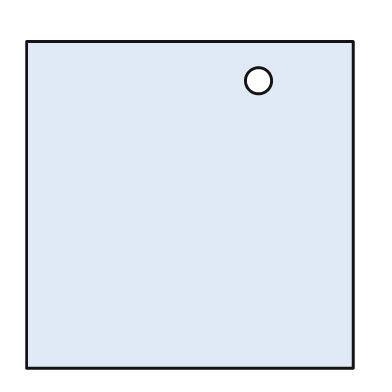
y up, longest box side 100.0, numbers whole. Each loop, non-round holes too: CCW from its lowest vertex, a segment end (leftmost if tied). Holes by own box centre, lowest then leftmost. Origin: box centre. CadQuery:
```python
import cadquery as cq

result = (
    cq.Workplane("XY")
    .moveTo(-50.0, -50.0)
    .lineTo(50.0, -50.0)
    .lineTo(50.0, 50.0)
    .lineTo(-50.0, 50.0)
    .close()
    .moveTo(21.0, 38.0)
    .circle(4.0)
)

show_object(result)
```